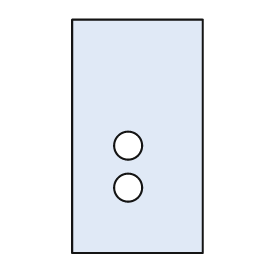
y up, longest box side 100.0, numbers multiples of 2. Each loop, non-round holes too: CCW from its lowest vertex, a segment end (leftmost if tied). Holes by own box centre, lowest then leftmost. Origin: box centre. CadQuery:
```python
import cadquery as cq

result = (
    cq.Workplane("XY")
    .moveTo(-28.0, -50.0)
    .lineTo(28.0, -50.0)
    .lineTo(28.0, 50.0)
    .lineTo(-28.0, 50.0)
    .close()
    .moveTo(-4.0, -22.0)
    .circle(6.0)
    .moveTo(-4.0, -4.0)
    .circle(6.0)
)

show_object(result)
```